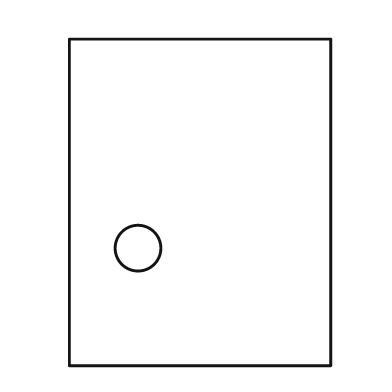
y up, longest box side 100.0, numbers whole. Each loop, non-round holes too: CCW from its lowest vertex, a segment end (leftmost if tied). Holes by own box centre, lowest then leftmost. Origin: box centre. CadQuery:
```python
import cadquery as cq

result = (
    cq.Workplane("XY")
    .moveTo(-40.0, -50.0)
    .lineTo(40.0, -50.0)
    .lineTo(40.0, 50.0)
    .lineTo(-40.0, 50.0)
    .close()
    .moveTo(-19.0, -14.0)
    .circle(7.0)
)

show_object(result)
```